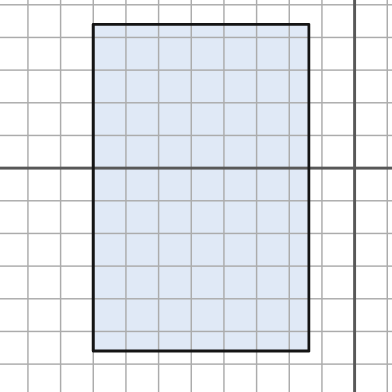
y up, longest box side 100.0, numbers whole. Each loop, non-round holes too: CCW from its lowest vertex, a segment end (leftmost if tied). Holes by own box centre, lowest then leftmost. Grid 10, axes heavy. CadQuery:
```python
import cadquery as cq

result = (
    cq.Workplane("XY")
    .moveTo(-80.0, -56.0)
    .lineTo(-14.0, -56.0)
    .lineTo(-14.0, 44.0)
    .lineTo(-80.0, 44.0)
    .close()
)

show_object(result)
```